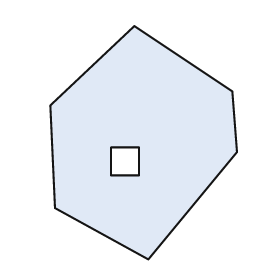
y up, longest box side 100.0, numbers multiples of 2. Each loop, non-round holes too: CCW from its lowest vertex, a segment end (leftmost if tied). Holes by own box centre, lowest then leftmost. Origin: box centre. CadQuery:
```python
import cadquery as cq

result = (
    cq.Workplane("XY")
    .moveTo(2.0, -50.0)
    .lineTo(40.0, -4.0)
    .lineTo(38.0, 22.0)
    .lineTo(-4.0, 50.0)
    .lineTo(-40.0, 16.0)
    .lineTo(-38.0, -28.0)
    .close()
    .moveTo(-14.0, -14.0)
    .lineTo(-2.0, -14.0)
    .lineTo(-2.0, -2.0)
    .lineTo(-14.0, -2.0)
    .close()
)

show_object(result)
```